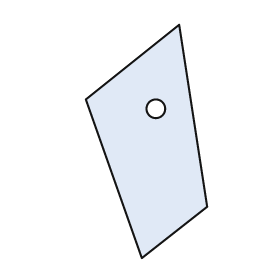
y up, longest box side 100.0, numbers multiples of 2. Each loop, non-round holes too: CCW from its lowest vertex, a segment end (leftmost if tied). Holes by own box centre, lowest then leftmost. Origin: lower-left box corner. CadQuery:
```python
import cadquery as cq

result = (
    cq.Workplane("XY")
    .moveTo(24.0, 0.0)
    .lineTo(52.0, 22.0)
    .lineTo(40.0, 100.0)
    .lineTo(0.0, 68.0)
    .close()
    .moveTo(30.0, 64.0)
    .circle(4.0)
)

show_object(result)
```